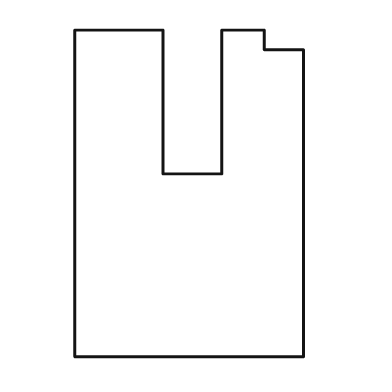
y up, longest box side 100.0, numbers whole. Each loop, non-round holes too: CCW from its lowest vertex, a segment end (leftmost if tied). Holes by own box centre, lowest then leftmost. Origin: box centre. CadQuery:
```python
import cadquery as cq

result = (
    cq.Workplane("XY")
    .moveTo(-35.0, -50.0)
    .lineTo(35.0, -50.0)
    .lineTo(35.0, 44.0)
    .lineTo(23.0, 44.0)
    .lineTo(23.0, 50.0)
    .lineTo(10.0, 50.0)
    .lineTo(10.0, 6.0)
    .lineTo(-8.0, 6.0)
    .lineTo(-8.0, 50.0)
    .lineTo(-35.0, 50.0)
    .close()
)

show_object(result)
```